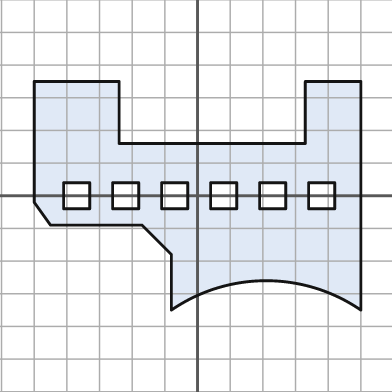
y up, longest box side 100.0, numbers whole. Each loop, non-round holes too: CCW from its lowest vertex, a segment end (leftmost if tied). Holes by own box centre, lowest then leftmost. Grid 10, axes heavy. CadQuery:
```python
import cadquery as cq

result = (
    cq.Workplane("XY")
    .moveTo(-8.0, -35.0)
    .threePointArc((21.0, -26.0), (50.0, -35.0))
    .lineTo(50.0, 35.0)
    .lineTo(33.0, 35.0)
    .lineTo(33.0, 16.0)
    .lineTo(-24.0, 16.0)
    .lineTo(-24.0, 35.0)
    .lineTo(-50.0, 35.0)
    .lineTo(-50.0, -2.0)
    .lineTo(-45.0, -9.0)
    .lineTo(-17.0, -9.0)
    .lineTo(-8.0, -18.0)
    .close()
    .moveTo(-41.0, -4.0)
    .lineTo(-33.0, -4.0)
    .lineTo(-33.0, 4.0)
    .lineTo(-41.0, 4.0)
    .close()
    .moveTo(-26.0, -4.0)
    .lineTo(-18.0, -4.0)
    .lineTo(-18.0, 4.0)
    .lineTo(-26.0, 4.0)
    .close()
    .moveTo(-11.0, -4.0)
    .lineTo(-3.0, -4.0)
    .lineTo(-3.0, 4.0)
    .lineTo(-11.0, 4.0)
    .close()
    .moveTo(4.0, -4.0)
    .lineTo(12.0, -4.0)
    .lineTo(12.0, 4.0)
    .lineTo(4.0, 4.0)
    .close()
    .moveTo(19.0, -4.0)
    .lineTo(27.0, -4.0)
    .lineTo(27.0, 4.0)
    .lineTo(19.0, 4.0)
    .close()
    .moveTo(34.0, -4.0)
    .lineTo(42.0, -4.0)
    .lineTo(42.0, 4.0)
    .lineTo(34.0, 4.0)
    .close()
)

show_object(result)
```